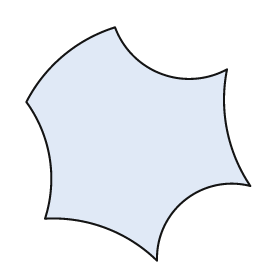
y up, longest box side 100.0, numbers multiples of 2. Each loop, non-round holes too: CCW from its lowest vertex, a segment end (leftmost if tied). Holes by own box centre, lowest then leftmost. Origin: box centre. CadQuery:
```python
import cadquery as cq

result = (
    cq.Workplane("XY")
    .moveTo(8.0, -50.0)
    .threePointArc((20.0, -24.0), (48.0, -18.0))
    .threePointArc((38.0, 6.0), (38.0, 32.0))
    .threePointArc((10.0, 30.0), (-10.0, 50.0))
    .threePointArc((-32.0, 38.0), (-48.0, 18.0))
    .threePointArc((-38.0, -6.0), (-40.0, -32.0))
    .threePointArc((-14.0, -36.0), (8.0, -50.0))
    .close()
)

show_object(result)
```